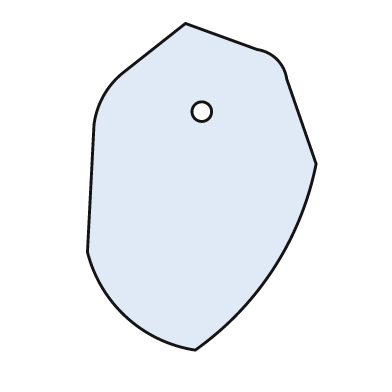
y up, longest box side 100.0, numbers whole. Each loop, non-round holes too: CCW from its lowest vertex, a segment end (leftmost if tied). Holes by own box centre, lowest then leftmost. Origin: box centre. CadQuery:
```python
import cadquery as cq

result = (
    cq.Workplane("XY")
    .moveTo(-2.0, -50.0)
    .threePointArc((22.0, -25.0), (35.0, 7.0))
    .lineTo(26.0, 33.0)
    .threePointArc((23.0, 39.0), (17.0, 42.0))
    .lineTo(-5.0, 50.0)
    .lineTo(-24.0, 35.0)
    .threePointArc((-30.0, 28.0), (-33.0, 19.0))
    .lineTo(-35.0, -20.0)
    .threePointArc((-23.0, -40.0), (-2.0, -50.0))
    .close()
    .moveTo(0.0, 23.0)
    .circle(3.0)
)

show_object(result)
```